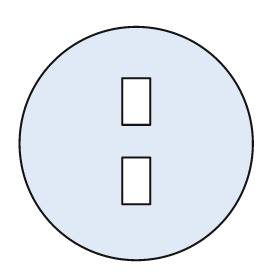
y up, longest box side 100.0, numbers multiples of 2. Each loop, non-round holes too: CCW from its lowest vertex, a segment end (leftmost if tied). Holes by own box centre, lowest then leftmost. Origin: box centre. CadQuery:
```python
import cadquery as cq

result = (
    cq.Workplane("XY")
    .moveTo(0.0, 0.0)
    .circle(50.0)
    .moveTo(-6.0, -26.0)
    .lineTo(6.0, -26.0)
    .lineTo(6.0, -6.0)
    .lineTo(-6.0, -6.0)
    .close()
    .moveTo(-6.0, 8.0)
    .lineTo(6.0, 8.0)
    .lineTo(6.0, 28.0)
    .lineTo(-6.0, 28.0)
    .close()
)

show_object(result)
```